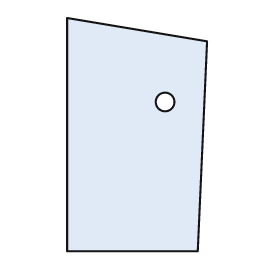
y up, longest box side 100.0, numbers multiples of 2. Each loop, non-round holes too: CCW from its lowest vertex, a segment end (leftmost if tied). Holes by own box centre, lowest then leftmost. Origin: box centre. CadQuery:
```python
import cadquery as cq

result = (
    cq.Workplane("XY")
    .moveTo(-30.0, -50.0)
    .lineTo(26.0, -50.0)
    .lineTo(30.0, 40.0)
    .lineTo(-30.0, 50.0)
    .close()
    .moveTo(12.0, 14.0)
    .circle(4.0)
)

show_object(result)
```